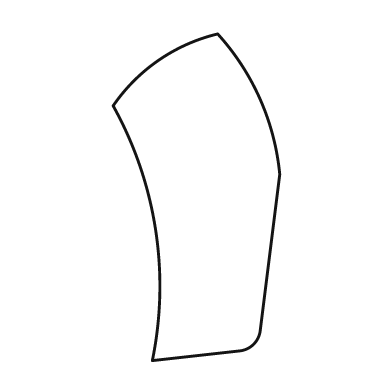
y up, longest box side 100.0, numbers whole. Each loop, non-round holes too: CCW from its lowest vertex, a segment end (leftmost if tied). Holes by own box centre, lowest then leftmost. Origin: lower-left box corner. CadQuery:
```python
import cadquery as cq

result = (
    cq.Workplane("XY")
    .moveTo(12.0, 0.0)
    .lineTo(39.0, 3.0)
    .threePointArc((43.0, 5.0), (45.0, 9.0))
    .lineTo(51.0, 57.0)
    .threePointArc((45.0, 80.0), (32.0, 100.0))
    .threePointArc((14.0, 92.0), (0.0, 78.0))
    .threePointArc((13.0, 40.0), (12.0, 0.0))
    .close()
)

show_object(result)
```